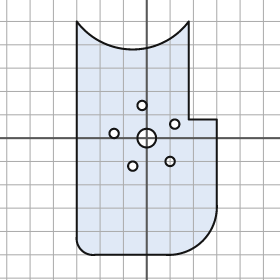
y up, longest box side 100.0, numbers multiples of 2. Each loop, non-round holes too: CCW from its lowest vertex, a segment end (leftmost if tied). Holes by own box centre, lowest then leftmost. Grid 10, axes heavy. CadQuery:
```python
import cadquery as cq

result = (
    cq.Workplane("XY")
    .moveTo(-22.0, -50.0)
    .lineTo(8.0, -50.0)
    .threePointArc((24.0, -44.0), (30.0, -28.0))
    .lineTo(30.0, 8.0)
    .lineTo(18.0, 8.0)
    .lineTo(18.0, 50.0)
    .threePointArc((-6.0, 38.0), (-30.0, 50.0))
    .lineTo(-30.0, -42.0)
    .threePointArc((-28.0, -48.0), (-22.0, -50.0))
    .close()
    .moveTo(-6.0, -12.0)
    .circle(2.0)
    .moveTo(10.0, -10.0)
    .circle(2.0)
    .moveTo(0.0, 0.0)
    .circle(4.0)
    .moveTo(-14.0, 2.0)
    .circle(2.0)
    .moveTo(12.0, 6.0)
    .circle(2.0)
    .moveTo(-2.0, 14.0)
    .circle(2.0)
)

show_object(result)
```